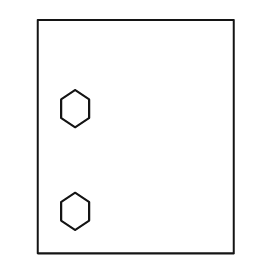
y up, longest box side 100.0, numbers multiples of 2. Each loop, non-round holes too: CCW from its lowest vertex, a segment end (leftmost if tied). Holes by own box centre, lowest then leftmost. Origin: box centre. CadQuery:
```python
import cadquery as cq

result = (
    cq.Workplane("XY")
    .moveTo(-42.0, -50.0)
    .lineTo(42.0, -50.0)
    .lineTo(42.0, 50.0)
    .lineTo(-42.0, 50.0)
    .close()
    .moveTo(-26.0, -40.0)
    .lineTo(-20.0, -36.0)
    .lineTo(-20.0, -28.0)
    .lineTo(-26.0, -24.0)
    .lineTo(-32.0, -28.0)
    .lineTo(-32.0, -36.0)
    .close()
    .moveTo(-26.0, 4.0)
    .lineTo(-20.0, 8.0)
    .lineTo(-20.0, 16.0)
    .lineTo(-26.0, 20.0)
    .lineTo(-32.0, 16.0)
    .lineTo(-32.0, 8.0)
    .close()
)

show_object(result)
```